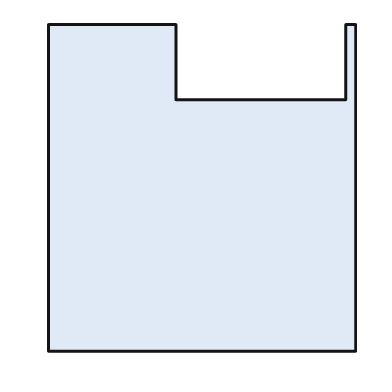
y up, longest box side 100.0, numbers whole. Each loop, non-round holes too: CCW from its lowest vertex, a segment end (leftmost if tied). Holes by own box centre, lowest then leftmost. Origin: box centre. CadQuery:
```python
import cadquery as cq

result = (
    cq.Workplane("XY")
    .moveTo(-47.0, -50.0)
    .lineTo(47.0, -50.0)
    .lineTo(47.0, 50.0)
    .lineTo(44.0, 50.0)
    .lineTo(44.0, 27.0)
    .lineTo(-8.0, 27.0)
    .lineTo(-8.0, 50.0)
    .lineTo(-47.0, 50.0)
    .close()
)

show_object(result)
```